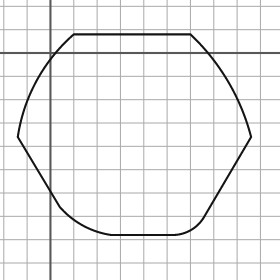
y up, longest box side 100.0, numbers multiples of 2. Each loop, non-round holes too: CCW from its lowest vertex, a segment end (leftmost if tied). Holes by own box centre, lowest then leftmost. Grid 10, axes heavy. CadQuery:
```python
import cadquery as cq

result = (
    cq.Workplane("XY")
    .moveTo(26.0, -78.0)
    .lineTo(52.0, -78.0)
    .threePointArc((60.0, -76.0), (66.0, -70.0))
    .lineTo(86.0, -36.0)
    .threePointArc((76.0, -12.0), (60.0, 8.0))
    .lineTo(10.0, 8.0)
    .threePointArc((-6.0, -12.0), (-14.0, -36.0))
    .lineTo(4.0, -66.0)
    .threePointArc((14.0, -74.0), (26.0, -78.0))
    .close()
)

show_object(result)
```